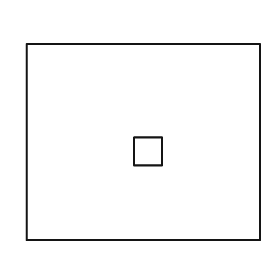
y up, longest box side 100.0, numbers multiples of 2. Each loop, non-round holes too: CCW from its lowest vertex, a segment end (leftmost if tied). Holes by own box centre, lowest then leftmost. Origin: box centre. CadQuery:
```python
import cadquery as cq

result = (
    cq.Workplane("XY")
    .moveTo(-50.0, -42.0)
    .lineTo(50.0, -42.0)
    .lineTo(50.0, 42.0)
    .lineTo(-50.0, 42.0)
    .close()
    .moveTo(-4.0, -10.0)
    .lineTo(8.0, -10.0)
    .lineTo(8.0, 2.0)
    .lineTo(-4.0, 2.0)
    .close()
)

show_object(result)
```